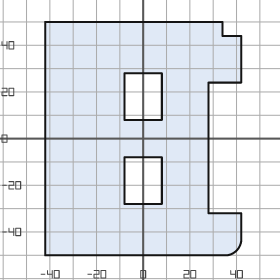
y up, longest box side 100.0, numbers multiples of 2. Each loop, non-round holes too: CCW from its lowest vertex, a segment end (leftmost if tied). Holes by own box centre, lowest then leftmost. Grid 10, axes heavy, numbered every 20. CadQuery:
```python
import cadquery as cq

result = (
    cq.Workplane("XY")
    .moveTo(-42.0, -50.0)
    .lineTo(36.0, -50.0)
    .threePointArc((40.0, -48.0), (42.0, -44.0))
    .lineTo(42.0, -32.0)
    .lineTo(28.0, -32.0)
    .lineTo(28.0, 24.0)
    .lineTo(42.0, 24.0)
    .lineTo(42.0, 44.0)
    .lineTo(34.0, 44.0)
    .lineTo(34.0, 50.0)
    .lineTo(-42.0, 50.0)
    .close()
    .moveTo(-8.0, -28.0)
    .lineTo(8.0, -28.0)
    .lineTo(8.0, -8.0)
    .lineTo(-8.0, -8.0)
    .close()
    .moveTo(-8.0, 8.0)
    .lineTo(8.0, 8.0)
    .lineTo(8.0, 28.0)
    .lineTo(-8.0, 28.0)
    .close()
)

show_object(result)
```